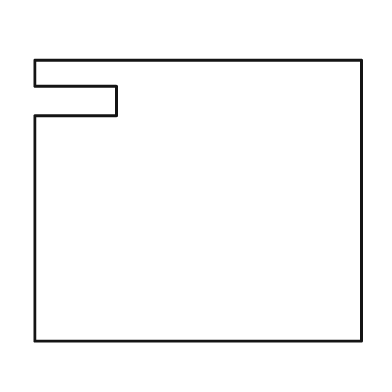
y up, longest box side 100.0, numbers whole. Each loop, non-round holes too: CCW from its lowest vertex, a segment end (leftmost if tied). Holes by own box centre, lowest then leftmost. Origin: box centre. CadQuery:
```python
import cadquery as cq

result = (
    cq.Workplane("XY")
    .moveTo(-50.0, -43.0)
    .lineTo(50.0, -43.0)
    .lineTo(50.0, 43.0)
    .lineTo(-50.0, 43.0)
    .lineTo(-50.0, 35.0)
    .lineTo(-25.0, 35.0)
    .lineTo(-25.0, 26.0)
    .lineTo(-50.0, 26.0)
    .close()
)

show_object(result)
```